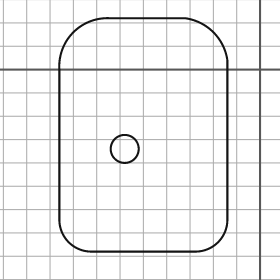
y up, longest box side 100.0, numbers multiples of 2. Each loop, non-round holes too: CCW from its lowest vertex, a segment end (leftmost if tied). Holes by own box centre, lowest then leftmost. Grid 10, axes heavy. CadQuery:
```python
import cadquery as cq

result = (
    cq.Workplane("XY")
    .moveTo(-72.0, -78.0)
    .lineTo(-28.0, -78.0)
    .threePointArc((-18.0, -74.0), (-14.0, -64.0))
    .lineTo(-14.0, 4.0)
    .threePointArc((-20.0, 16.0), (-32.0, 22.0))
    .lineTo(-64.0, 22.0)
    .threePointArc((-80.0, 16.0), (-86.0, 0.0))
    .lineTo(-86.0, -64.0)
    .threePointArc((-82.0, -74.0), (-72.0, -78.0))
    .close()
    .moveTo(-58.0, -34.0)
    .circle(6.0)
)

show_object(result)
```